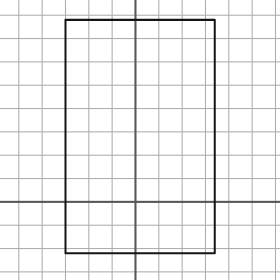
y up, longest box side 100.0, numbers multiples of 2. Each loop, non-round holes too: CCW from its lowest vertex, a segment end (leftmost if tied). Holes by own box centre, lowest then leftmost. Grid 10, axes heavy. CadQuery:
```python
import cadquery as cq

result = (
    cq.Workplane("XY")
    .moveTo(-30.0, -22.0)
    .lineTo(34.0, -22.0)
    .lineTo(34.0, 78.0)
    .lineTo(-30.0, 78.0)
    .close()
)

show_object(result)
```